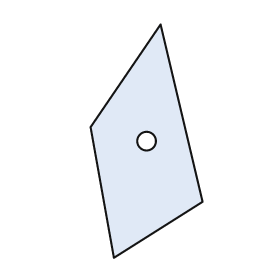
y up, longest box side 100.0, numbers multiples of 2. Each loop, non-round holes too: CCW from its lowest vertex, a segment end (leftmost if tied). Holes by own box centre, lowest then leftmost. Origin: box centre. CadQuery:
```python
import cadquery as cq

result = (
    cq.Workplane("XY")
    .moveTo(-14.0, -50.0)
    .lineTo(24.0, -26.0)
    .lineTo(6.0, 50.0)
    .lineTo(-24.0, 6.0)
    .close()
    .moveTo(0.0, 0.0)
    .circle(4.0)
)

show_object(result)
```